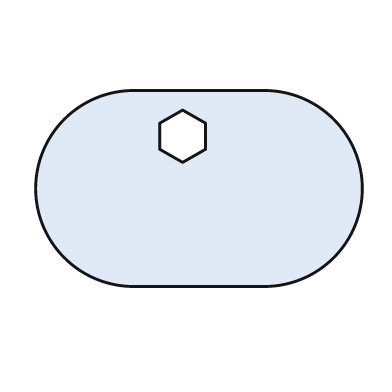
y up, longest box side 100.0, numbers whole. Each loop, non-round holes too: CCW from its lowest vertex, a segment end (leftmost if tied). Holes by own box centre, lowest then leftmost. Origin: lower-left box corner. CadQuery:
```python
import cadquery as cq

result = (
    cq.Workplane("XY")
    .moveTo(30.0, 0.0)
    .lineTo(70.0, 0.0)
    .threePointArc((100.0, 30.0), (70.0, 60.0))
    .lineTo(30.0, 60.0)
    .threePointArc((0.0, 30.0), (30.0, 0.0))
    .close()
    .moveTo(45.0, 38.0)
    .lineTo(52.0, 42.0)
    .lineTo(52.0, 50.0)
    .lineTo(45.0, 54.0)
    .lineTo(38.0, 50.0)
    .lineTo(38.0, 42.0)
    .close()
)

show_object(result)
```